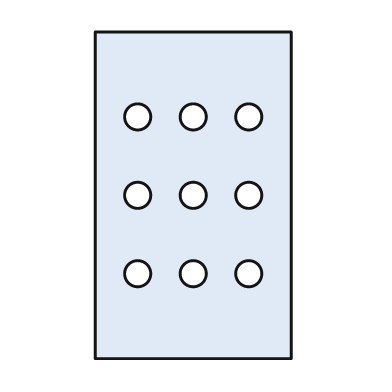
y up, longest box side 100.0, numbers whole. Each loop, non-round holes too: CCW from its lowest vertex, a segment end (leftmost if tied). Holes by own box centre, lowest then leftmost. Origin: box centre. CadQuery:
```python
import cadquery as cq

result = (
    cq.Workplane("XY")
    .moveTo(-30.0, -50.0)
    .lineTo(30.0, -50.0)
    .lineTo(30.0, 50.0)
    .lineTo(-30.0, 50.0)
    .close()
    .moveTo(-17.0, -24.0)
    .circle(4.0)
    .moveTo(0.0, -24.0)
    .circle(4.0)
    .moveTo(17.0, -24.0)
    .circle(4.0)
    .moveTo(-17.0, 0.0)
    .circle(4.0)
    .moveTo(0.0, 0.0)
    .circle(4.0)
    .moveTo(17.0, 0.0)
    .circle(4.0)
    .moveTo(-17.0, 24.0)
    .circle(4.0)
    .moveTo(0.0, 24.0)
    .circle(4.0)
    .moveTo(17.0, 24.0)
    .circle(4.0)
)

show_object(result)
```